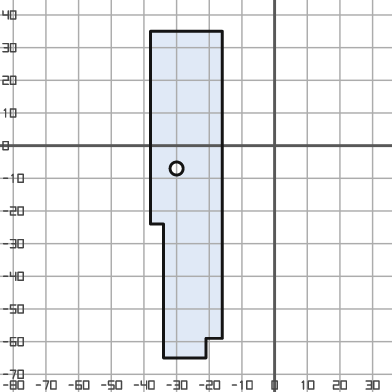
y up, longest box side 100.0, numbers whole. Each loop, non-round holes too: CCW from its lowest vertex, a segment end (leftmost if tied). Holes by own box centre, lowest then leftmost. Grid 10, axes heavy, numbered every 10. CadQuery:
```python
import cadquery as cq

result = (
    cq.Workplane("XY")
    .moveTo(-34.0, -65.0)
    .lineTo(-21.0, -65.0)
    .lineTo(-21.0, -59.0)
    .lineTo(-16.0, -59.0)
    .lineTo(-16.0, 35.0)
    .lineTo(-38.0, 35.0)
    .lineTo(-38.0, -24.0)
    .lineTo(-34.0, -24.0)
    .close()
    .moveTo(-30.0, -7.0)
    .circle(2.0)
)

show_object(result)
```